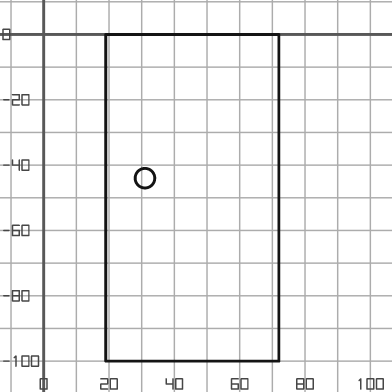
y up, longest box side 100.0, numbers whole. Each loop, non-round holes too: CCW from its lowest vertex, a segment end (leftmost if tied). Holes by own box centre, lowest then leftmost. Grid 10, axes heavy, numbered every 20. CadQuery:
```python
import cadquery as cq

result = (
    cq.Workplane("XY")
    .moveTo(19.0, -100.0)
    .lineTo(72.0, -100.0)
    .lineTo(72.0, 0.0)
    .lineTo(19.0, 0.0)
    .close()
    .moveTo(31.0, -44.0)
    .circle(3.0)
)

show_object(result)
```